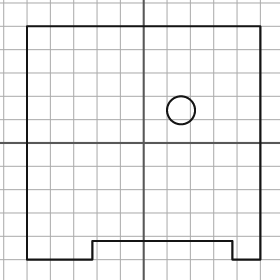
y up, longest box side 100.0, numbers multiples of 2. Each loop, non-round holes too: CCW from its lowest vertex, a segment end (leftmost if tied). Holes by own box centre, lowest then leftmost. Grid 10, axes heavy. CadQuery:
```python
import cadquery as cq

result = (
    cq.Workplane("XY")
    .moveTo(-50.0, -50.0)
    .lineTo(-22.0, -50.0)
    .lineTo(-22.0, -42.0)
    .lineTo(38.0, -42.0)
    .lineTo(38.0, -50.0)
    .lineTo(50.0, -50.0)
    .lineTo(50.0, 50.0)
    .lineTo(-50.0, 50.0)
    .close()
    .moveTo(16.0, 14.0)
    .circle(6.0)
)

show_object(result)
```